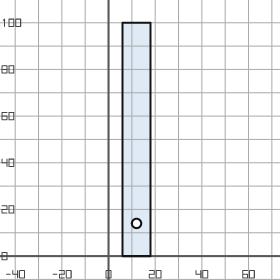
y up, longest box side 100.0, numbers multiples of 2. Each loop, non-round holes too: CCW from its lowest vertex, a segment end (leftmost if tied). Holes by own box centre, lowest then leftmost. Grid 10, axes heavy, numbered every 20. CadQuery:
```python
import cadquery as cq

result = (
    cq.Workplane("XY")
    .moveTo(6.0, 0.0)
    .lineTo(18.0, 0.0)
    .lineTo(18.0, 100.0)
    .lineTo(6.0, 100.0)
    .close()
    .moveTo(12.0, 14.0)
    .circle(2.0)
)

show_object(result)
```